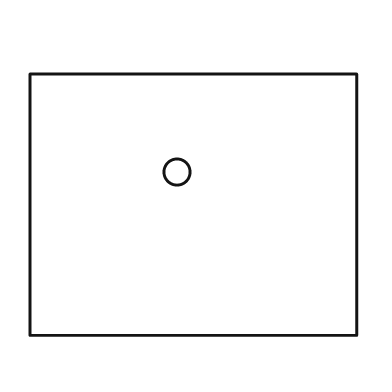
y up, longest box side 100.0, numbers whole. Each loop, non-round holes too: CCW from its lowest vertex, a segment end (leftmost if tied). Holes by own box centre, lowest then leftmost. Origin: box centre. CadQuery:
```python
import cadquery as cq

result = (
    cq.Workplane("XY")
    .moveTo(-50.0, -40.0)
    .lineTo(50.0, -40.0)
    .lineTo(50.0, 40.0)
    .lineTo(-50.0, 40.0)
    .close()
    .moveTo(-5.0, 10.0)
    .circle(4.0)
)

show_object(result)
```